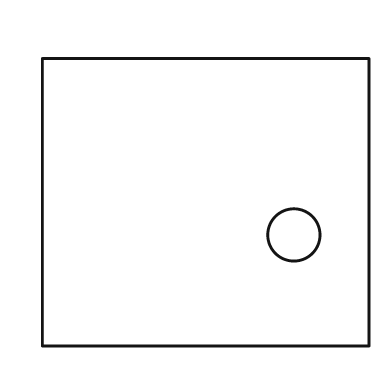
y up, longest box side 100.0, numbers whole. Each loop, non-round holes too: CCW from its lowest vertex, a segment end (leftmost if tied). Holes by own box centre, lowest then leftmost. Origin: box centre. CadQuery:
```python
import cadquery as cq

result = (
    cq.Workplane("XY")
    .moveTo(-50.0, -44.0)
    .lineTo(50.0, -44.0)
    .lineTo(50.0, 44.0)
    .lineTo(-50.0, 44.0)
    .close()
    .moveTo(27.0, -10.0)
    .circle(8.0)
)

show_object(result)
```